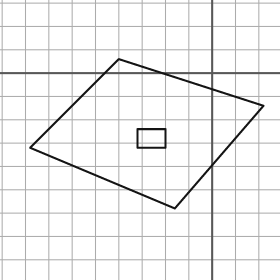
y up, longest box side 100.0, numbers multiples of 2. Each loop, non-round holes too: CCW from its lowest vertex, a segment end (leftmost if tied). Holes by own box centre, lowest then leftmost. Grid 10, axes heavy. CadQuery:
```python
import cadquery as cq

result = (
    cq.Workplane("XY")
    .moveTo(-16.0, -58.0)
    .lineTo(22.0, -14.0)
    .lineTo(-40.0, 6.0)
    .lineTo(-78.0, -32.0)
    .close()
    .moveTo(-32.0, -32.0)
    .lineTo(-20.0, -32.0)
    .lineTo(-20.0, -24.0)
    .lineTo(-32.0, -24.0)
    .close()
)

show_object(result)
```